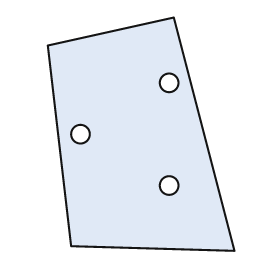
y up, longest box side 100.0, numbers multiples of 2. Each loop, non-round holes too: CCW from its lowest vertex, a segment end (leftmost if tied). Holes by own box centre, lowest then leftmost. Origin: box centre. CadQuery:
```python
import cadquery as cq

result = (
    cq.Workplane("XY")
    .moveTo(40.0, -50.0)
    .lineTo(14.0, 50.0)
    .lineTo(-40.0, 38.0)
    .lineTo(-30.0, -48.0)
    .close()
    .moveTo(12.0, -22.0)
    .circle(4.0)
    .moveTo(-26.0, 0.0)
    .circle(4.0)
    .moveTo(12.0, 22.0)
    .circle(4.0)
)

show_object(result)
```